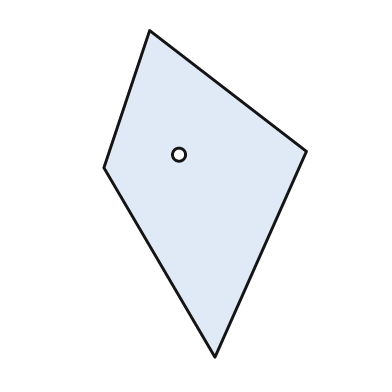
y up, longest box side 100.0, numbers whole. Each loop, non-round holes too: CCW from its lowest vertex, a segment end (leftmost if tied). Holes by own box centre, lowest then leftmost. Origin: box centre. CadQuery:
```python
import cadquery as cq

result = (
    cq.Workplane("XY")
    .moveTo(3.0, -50.0)
    .lineTo(31.0, 13.0)
    .lineTo(-17.0, 50.0)
    .lineTo(-31.0, 8.0)
    .close()
    .moveTo(-8.0, 12.0)
    .circle(2.0)
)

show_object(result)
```